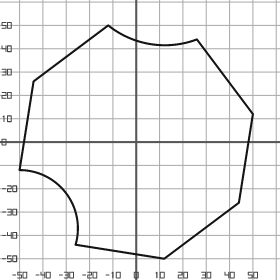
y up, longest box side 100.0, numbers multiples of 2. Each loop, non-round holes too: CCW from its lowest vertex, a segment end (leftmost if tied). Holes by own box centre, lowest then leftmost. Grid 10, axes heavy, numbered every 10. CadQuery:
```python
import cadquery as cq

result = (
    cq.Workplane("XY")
    .moveTo(12.0, -50.0)
    .lineTo(44.0, -26.0)
    .lineTo(50.0, 12.0)
    .lineTo(26.0, 44.0)
    .threePointArc((6.0, 42.0), (-12.0, 50.0))
    .lineTo(-44.0, 26.0)
    .lineTo(-50.0, -12.0)
    .threePointArc((-30.0, -22.0), (-26.0, -44.0))
    .close()
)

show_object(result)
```